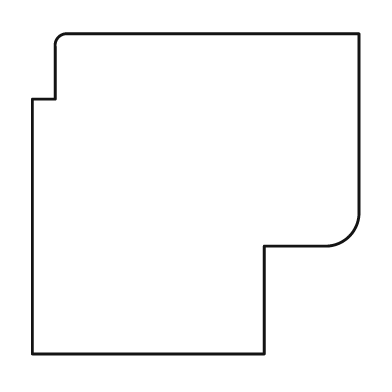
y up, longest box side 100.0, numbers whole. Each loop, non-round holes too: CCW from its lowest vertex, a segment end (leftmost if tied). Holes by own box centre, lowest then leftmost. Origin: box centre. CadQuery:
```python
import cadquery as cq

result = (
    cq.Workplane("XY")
    .moveTo(-50.0, -49.0)
    .lineTo(21.0, -49.0)
    .lineTo(21.0, -16.0)
    .lineTo(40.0, -16.0)
    .threePointArc((47.0, -13.0), (50.0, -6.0))
    .lineTo(50.0, 49.0)
    .lineTo(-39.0, 49.0)
    .threePointArc((-42.0, 48.0), (-43.0, 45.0))
    .lineTo(-43.0, 29.0)
    .lineTo(-50.0, 29.0)
    .close()
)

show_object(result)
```